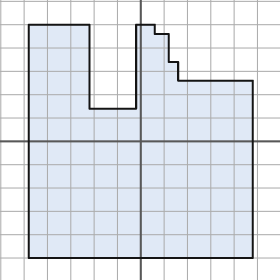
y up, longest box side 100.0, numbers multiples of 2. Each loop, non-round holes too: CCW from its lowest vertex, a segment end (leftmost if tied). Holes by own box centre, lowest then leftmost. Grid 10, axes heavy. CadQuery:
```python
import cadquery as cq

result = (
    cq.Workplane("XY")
    .moveTo(-48.0, -50.0)
    .lineTo(48.0, -50.0)
    .lineTo(48.0, 26.0)
    .lineTo(16.0, 26.0)
    .lineTo(16.0, 34.0)
    .lineTo(12.0, 34.0)
    .lineTo(12.0, 46.0)
    .lineTo(6.0, 46.0)
    .lineTo(6.0, 50.0)
    .lineTo(-2.0, 50.0)
    .lineTo(-2.0, 14.0)
    .lineTo(-22.0, 14.0)
    .lineTo(-22.0, 50.0)
    .lineTo(-48.0, 50.0)
    .close()
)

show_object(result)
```